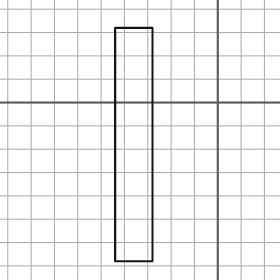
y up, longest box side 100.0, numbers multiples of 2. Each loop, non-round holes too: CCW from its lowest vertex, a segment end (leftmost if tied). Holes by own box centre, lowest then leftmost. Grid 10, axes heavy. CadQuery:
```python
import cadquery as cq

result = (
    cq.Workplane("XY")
    .moveTo(-44.0, -68.0)
    .lineTo(-28.0, -68.0)
    .lineTo(-28.0, 32.0)
    .lineTo(-44.0, 32.0)
    .close()
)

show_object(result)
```